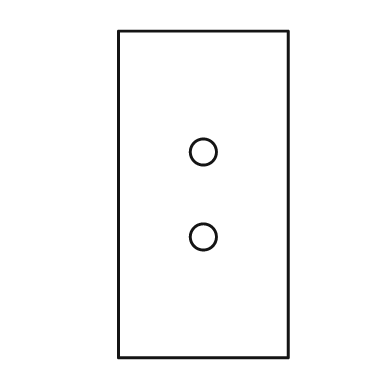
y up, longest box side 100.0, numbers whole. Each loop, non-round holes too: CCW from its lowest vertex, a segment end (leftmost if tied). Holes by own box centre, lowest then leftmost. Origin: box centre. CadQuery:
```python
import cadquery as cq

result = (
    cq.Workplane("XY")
    .moveTo(-26.0, -50.0)
    .lineTo(26.0, -50.0)
    .lineTo(26.0, 50.0)
    .lineTo(-26.0, 50.0)
    .close()
    .moveTo(0.0, -13.0)
    .circle(4.0)
    .moveTo(0.0, 13.0)
    .circle(4.0)
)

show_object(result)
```